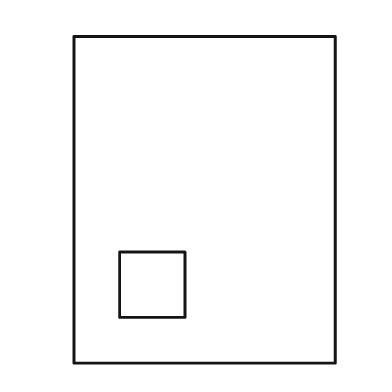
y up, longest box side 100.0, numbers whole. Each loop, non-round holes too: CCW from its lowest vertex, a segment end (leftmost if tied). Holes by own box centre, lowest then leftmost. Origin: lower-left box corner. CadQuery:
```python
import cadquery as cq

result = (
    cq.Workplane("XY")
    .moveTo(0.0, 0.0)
    .lineTo(80.0, 0.0)
    .lineTo(80.0, 100.0)
    .lineTo(0.0, 100.0)
    .close()
    .moveTo(14.0, 14.0)
    .lineTo(34.0, 14.0)
    .lineTo(34.0, 34.0)
    .lineTo(14.0, 34.0)
    .close()
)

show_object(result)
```